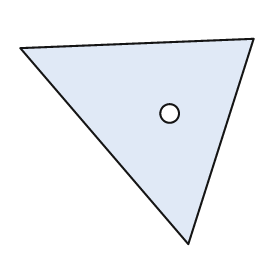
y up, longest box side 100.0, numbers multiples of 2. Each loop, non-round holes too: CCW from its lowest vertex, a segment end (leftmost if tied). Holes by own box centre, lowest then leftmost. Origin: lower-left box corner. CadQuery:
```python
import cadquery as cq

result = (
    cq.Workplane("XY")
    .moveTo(72.0, 0.0)
    .lineTo(100.0, 88.0)
    .lineTo(0.0, 84.0)
    .close()
    .moveTo(64.0, 56.0)
    .circle(4.0)
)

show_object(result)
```